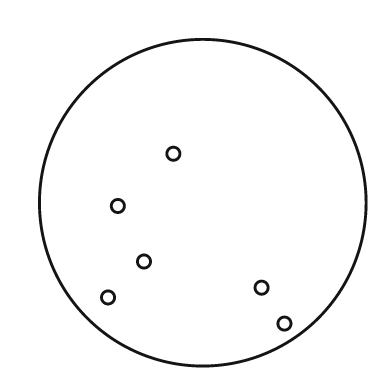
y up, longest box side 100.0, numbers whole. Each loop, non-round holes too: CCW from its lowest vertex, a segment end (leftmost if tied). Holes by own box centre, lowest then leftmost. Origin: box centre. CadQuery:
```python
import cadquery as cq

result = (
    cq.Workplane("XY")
    .moveTo(0.0, 0.0)
    .circle(50.0)
    .moveTo(25.0, -37.0)
    .circle(2.0)
    .moveTo(-29.0, -29.0)
    .circle(2.0)
    .moveTo(18.0, -26.0)
    .circle(2.0)
    .moveTo(-18.0, -18.0)
    .circle(2.0)
    .moveTo(-26.0, -1.0)
    .circle(2.0)
    .moveTo(-9.0, 15.0)
    .circle(2.0)
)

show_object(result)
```